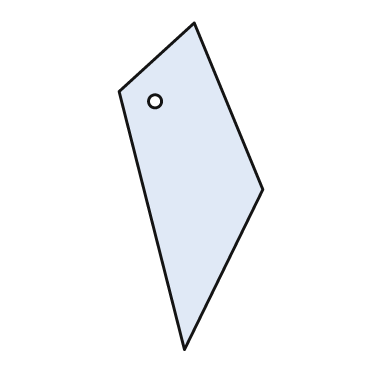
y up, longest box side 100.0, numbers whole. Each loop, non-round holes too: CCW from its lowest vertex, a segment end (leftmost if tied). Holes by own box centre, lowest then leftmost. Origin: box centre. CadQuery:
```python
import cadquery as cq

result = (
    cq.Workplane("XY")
    .moveTo(-2.0, -50.0)
    .lineTo(22.0, -1.0)
    .lineTo(1.0, 50.0)
    .lineTo(-22.0, 29.0)
    .close()
    .moveTo(-11.0, 26.0)
    .circle(2.0)
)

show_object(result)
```